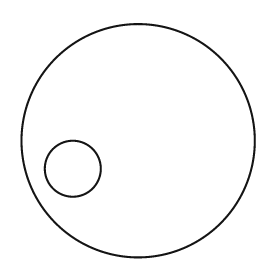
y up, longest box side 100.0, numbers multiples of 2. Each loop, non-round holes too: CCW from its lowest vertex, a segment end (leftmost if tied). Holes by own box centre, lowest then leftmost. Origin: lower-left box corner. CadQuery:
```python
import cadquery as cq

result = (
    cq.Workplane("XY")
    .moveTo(50.0, 50.0)
    .circle(50.0)
    .moveTo(22.0, 38.0)
    .circle(12.0)
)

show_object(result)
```